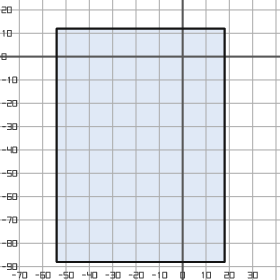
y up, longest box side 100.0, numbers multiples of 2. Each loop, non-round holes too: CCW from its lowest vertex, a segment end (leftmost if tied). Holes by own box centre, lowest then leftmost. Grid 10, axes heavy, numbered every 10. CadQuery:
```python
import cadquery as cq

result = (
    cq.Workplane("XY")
    .moveTo(-54.0, -88.0)
    .lineTo(18.0, -88.0)
    .lineTo(18.0, 12.0)
    .lineTo(-54.0, 12.0)
    .close()
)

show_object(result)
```